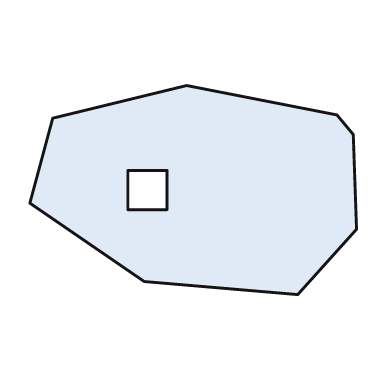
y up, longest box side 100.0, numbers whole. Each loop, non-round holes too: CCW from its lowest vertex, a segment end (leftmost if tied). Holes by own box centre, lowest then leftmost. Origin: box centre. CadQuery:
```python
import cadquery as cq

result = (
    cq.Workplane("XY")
    .moveTo(32.0, -32.0)
    .lineTo(50.0, -12.0)
    .lineTo(49.0, 17.0)
    .lineTo(44.0, 23.0)
    .lineTo(-2.0, 32.0)
    .lineTo(-43.0, 22.0)
    .lineTo(-50.0, -4.0)
    .lineTo(-15.0, -28.0)
    .close()
    .moveTo(-20.0, -6.0)
    .lineTo(-8.0, -6.0)
    .lineTo(-8.0, 6.0)
    .lineTo(-20.0, 6.0)
    .close()
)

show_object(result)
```